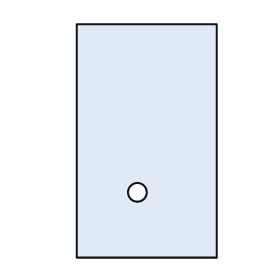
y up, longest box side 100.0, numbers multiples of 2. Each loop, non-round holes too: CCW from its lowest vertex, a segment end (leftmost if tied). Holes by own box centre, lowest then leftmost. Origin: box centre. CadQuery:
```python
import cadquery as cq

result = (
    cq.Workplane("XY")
    .moveTo(-30.0, -50.0)
    .lineTo(30.0, -50.0)
    .lineTo(30.0, 50.0)
    .lineTo(-30.0, 50.0)
    .close()
    .moveTo(-4.0, -22.0)
    .circle(4.0)
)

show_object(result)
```